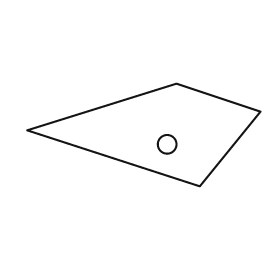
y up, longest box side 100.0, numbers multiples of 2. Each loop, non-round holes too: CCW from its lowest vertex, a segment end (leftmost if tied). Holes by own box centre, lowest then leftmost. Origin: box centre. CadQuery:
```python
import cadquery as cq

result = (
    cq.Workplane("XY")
    .moveTo(24.0, -22.0)
    .lineTo(50.0, 10.0)
    .lineTo(14.0, 22.0)
    .lineTo(-50.0, 2.0)
    .close()
    .moveTo(10.0, -4.0)
    .circle(4.0)
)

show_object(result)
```